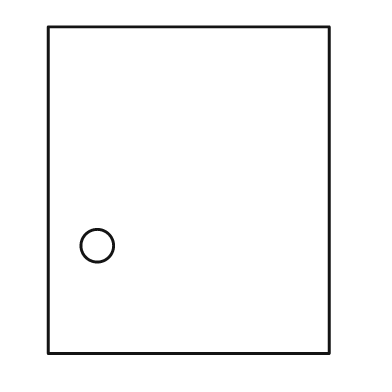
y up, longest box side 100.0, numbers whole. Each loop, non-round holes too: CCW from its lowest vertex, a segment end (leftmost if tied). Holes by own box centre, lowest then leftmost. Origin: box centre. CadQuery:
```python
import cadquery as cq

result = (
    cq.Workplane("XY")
    .moveTo(-43.0, -50.0)
    .lineTo(43.0, -50.0)
    .lineTo(43.0, 50.0)
    .lineTo(-43.0, 50.0)
    .close()
    .moveTo(-28.0, -17.0)
    .circle(5.0)
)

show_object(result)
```